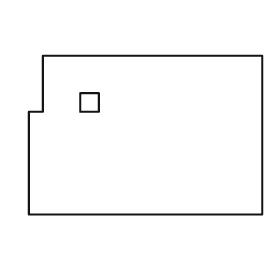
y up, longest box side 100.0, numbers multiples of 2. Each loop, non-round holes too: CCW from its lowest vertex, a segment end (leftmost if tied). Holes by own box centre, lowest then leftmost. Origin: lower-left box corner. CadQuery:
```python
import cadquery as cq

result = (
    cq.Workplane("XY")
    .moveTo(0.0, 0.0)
    .lineTo(100.0, 0.0)
    .lineTo(100.0, 68.0)
    .lineTo(6.0, 68.0)
    .lineTo(6.0, 44.0)
    .lineTo(0.0, 44.0)
    .close()
    .moveTo(22.0, 44.0)
    .lineTo(30.0, 44.0)
    .lineTo(30.0, 52.0)
    .lineTo(22.0, 52.0)
    .close()
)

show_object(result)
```